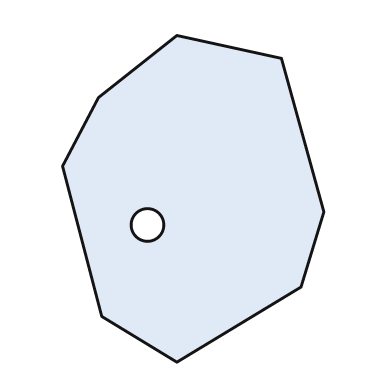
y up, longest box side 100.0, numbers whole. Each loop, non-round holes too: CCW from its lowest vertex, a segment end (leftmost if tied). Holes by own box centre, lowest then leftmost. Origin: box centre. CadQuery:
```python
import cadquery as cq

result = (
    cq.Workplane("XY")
    .moveTo(-5.0, -50.0)
    .lineTo(33.0, -27.0)
    .lineTo(40.0, -4.0)
    .lineTo(27.0, 43.0)
    .lineTo(-5.0, 50.0)
    .lineTo(-29.0, 31.0)
    .lineTo(-40.0, 10.0)
    .lineTo(-28.0, -36.0)
    .close()
    .moveTo(-14.0, -8.0)
    .circle(5.0)
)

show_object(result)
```